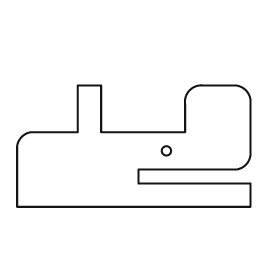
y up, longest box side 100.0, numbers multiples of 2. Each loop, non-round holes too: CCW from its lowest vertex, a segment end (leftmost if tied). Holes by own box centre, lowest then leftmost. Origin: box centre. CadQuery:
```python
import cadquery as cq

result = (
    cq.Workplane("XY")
    .moveTo(-50.0, -26.0)
    .lineTo(50.0, -26.0)
    .lineTo(50.0, -16.0)
    .lineTo(2.0, -16.0)
    .lineTo(2.0, -10.0)
    .lineTo(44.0, -10.0)
    .threePointArc((48.0, -8.0), (50.0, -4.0))
    .lineTo(50.0, 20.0)
    .threePointArc((48.0, 24.0), (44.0, 26.0))
    .lineTo(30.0, 26.0)
    .threePointArc((24.0, 24.0), (22.0, 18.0))
    .lineTo(22.0, 6.0)
    .lineTo(-14.0, 6.0)
    .lineTo(-14.0, 26.0)
    .lineTo(-24.0, 26.0)
    .lineTo(-24.0, 6.0)
    .lineTo(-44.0, 6.0)
    .threePointArc((-48.0, 4.0), (-50.0, 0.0))
    .close()
    .moveTo(14.0, -2.0)
    .circle(2.0)
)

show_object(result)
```